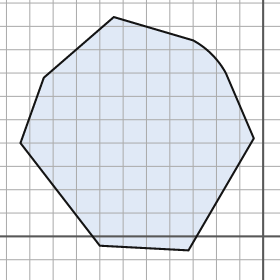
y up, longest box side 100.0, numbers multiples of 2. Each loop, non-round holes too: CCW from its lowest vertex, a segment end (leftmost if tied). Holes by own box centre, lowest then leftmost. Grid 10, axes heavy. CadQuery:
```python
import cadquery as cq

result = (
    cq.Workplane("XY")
    .moveTo(-32.0, -6.0)
    .lineTo(-4.0, 42.0)
    .lineTo(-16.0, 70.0)
    .threePointArc((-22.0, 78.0), (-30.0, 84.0))
    .lineTo(-64.0, 94.0)
    .lineTo(-94.0, 68.0)
    .lineTo(-104.0, 40.0)
    .lineTo(-70.0, -4.0)
    .close()
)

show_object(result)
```